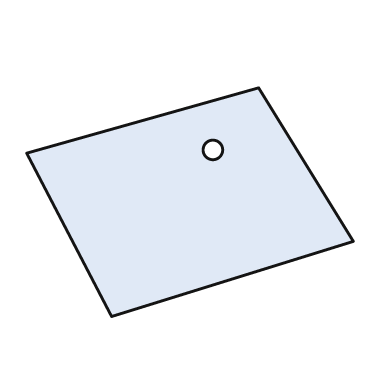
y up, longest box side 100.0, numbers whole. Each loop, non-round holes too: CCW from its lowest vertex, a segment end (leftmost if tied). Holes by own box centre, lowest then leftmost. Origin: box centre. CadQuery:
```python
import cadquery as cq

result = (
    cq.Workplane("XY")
    .moveTo(-24.0, -35.0)
    .lineTo(50.0, -12.0)
    .lineTo(21.0, 35.0)
    .lineTo(-50.0, 15.0)
    .close()
    .moveTo(7.0, 16.0)
    .circle(3.0)
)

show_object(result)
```